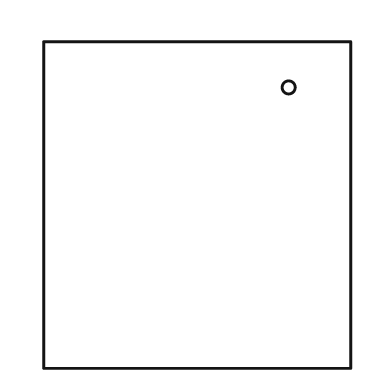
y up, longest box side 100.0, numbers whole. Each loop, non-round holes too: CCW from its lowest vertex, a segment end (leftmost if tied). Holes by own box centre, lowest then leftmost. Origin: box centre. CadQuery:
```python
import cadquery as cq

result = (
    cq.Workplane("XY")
    .moveTo(-47.0, -50.0)
    .lineTo(47.0, -50.0)
    .lineTo(47.0, 50.0)
    .lineTo(-47.0, 50.0)
    .close()
    .moveTo(28.0, 36.0)
    .circle(2.0)
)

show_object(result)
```